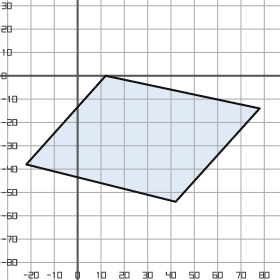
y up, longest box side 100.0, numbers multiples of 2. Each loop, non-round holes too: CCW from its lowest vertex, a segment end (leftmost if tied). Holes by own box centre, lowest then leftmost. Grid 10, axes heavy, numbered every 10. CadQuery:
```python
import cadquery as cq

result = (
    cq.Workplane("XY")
    .moveTo(42.0, -54.0)
    .lineTo(78.0, -14.0)
    .lineTo(12.0, 0.0)
    .lineTo(-22.0, -38.0)
    .close()
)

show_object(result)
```